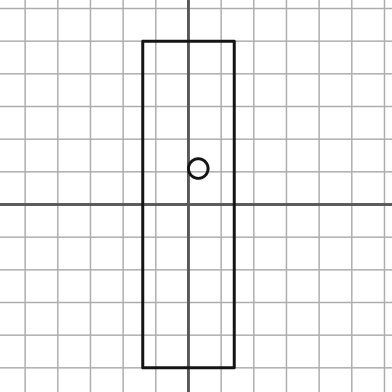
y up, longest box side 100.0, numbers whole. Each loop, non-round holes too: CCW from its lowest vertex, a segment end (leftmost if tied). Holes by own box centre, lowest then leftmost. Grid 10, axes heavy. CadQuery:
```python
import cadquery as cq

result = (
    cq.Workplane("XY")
    .moveTo(-14.0, -50.0)
    .lineTo(14.0, -50.0)
    .lineTo(14.0, 50.0)
    .lineTo(-14.0, 50.0)
    .close()
    .moveTo(3.0, 11.0)
    .circle(3.0)
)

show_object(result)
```